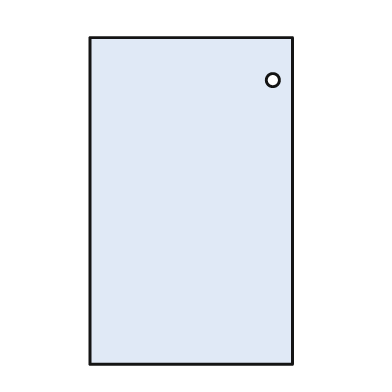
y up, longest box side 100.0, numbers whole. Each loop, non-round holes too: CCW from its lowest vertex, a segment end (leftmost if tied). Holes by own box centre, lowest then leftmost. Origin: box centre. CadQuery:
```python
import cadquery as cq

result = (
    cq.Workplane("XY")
    .moveTo(-31.0, -50.0)
    .lineTo(31.0, -50.0)
    .lineTo(31.0, 50.0)
    .lineTo(-31.0, 50.0)
    .close()
    .moveTo(25.0, 37.0)
    .circle(2.0)
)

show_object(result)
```